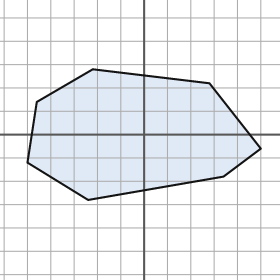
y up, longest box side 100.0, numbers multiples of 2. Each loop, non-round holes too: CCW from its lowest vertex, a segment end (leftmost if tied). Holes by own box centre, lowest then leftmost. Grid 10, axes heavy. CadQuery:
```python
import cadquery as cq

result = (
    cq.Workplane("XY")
    .moveTo(-24.0, -28.0)
    .lineTo(34.0, -18.0)
    .lineTo(50.0, -6.0)
    .lineTo(28.0, 22.0)
    .lineTo(-22.0, 28.0)
    .lineTo(-46.0, 14.0)
    .lineTo(-50.0, -12.0)
    .close()
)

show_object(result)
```